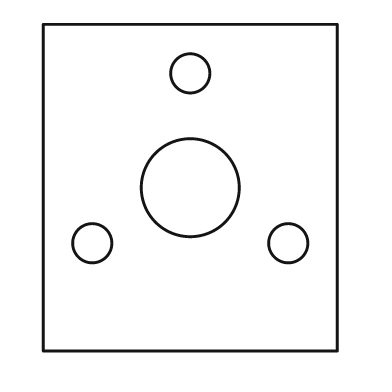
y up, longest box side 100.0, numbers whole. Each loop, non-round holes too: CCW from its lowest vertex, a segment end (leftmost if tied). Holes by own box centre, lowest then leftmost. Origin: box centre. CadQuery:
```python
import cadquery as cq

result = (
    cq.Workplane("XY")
    .moveTo(-45.0, -50.0)
    .lineTo(45.0, -50.0)
    .lineTo(45.0, 50.0)
    .lineTo(-45.0, 50.0)
    .close()
    .moveTo(-30.0, -17.0)
    .circle(6.0)
    .moveTo(30.0, -17.0)
    .circle(6.0)
    .moveTo(0.0, 0.0)
    .circle(15.0)
    .moveTo(0.0, 35.0)
    .circle(6.0)
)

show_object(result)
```